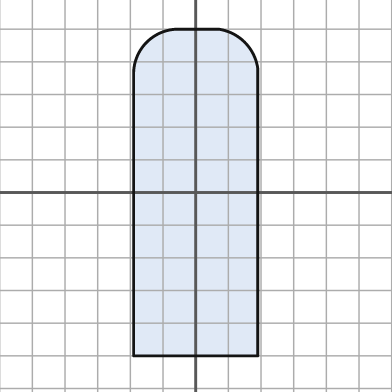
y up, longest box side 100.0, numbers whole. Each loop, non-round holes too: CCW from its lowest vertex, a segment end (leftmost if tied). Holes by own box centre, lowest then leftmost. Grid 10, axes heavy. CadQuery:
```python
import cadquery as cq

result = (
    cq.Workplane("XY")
    .moveTo(-19.0, -50.0)
    .lineTo(19.0, -50.0)
    .lineTo(19.0, 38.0)
    .threePointArc((15.0, 46.0), (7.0, 50.0))
    .lineTo(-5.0, 50.0)
    .threePointArc((-15.0, 46.0), (-19.0, 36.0))
    .close()
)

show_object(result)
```